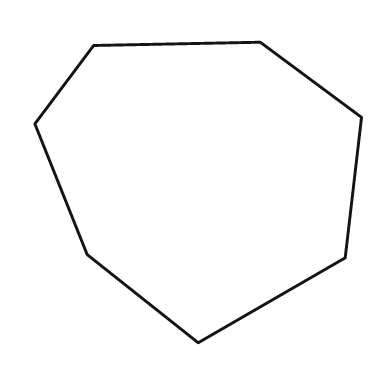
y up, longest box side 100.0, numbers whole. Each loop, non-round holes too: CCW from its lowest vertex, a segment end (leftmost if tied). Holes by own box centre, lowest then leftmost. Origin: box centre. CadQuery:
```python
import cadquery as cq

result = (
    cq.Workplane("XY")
    .moveTo(0.0, -46.0)
    .lineTo(45.0, -20.0)
    .lineTo(50.0, 23.0)
    .lineTo(19.0, 46.0)
    .lineTo(-32.0, 45.0)
    .lineTo(-50.0, 21.0)
    .lineTo(-34.0, -19.0)
    .close()
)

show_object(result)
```